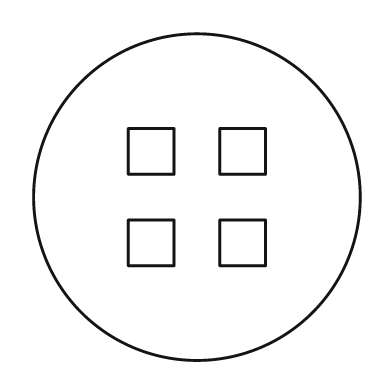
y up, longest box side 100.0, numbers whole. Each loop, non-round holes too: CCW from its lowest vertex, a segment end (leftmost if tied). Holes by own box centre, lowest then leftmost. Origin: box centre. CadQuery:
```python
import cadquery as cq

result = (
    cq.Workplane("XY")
    .moveTo(0.0, 0.0)
    .circle(50.0)
    .moveTo(-21.0, -21.0)
    .lineTo(-7.0, -21.0)
    .lineTo(-7.0, -7.0)
    .lineTo(-21.0, -7.0)
    .close()
    .moveTo(7.0, -21.0)
    .lineTo(21.0, -21.0)
    .lineTo(21.0, -7.0)
    .lineTo(7.0, -7.0)
    .close()
    .moveTo(-21.0, 7.0)
    .lineTo(-7.0, 7.0)
    .lineTo(-7.0, 21.0)
    .lineTo(-21.0, 21.0)
    .close()
    .moveTo(7.0, 7.0)
    .lineTo(21.0, 7.0)
    .lineTo(21.0, 21.0)
    .lineTo(7.0, 21.0)
    .close()
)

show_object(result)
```